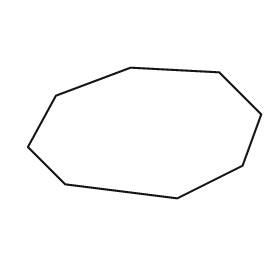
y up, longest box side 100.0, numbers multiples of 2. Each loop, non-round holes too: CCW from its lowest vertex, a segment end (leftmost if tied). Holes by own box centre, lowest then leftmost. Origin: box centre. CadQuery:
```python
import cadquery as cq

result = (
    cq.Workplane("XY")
    .moveTo(14.0, -28.0)
    .lineTo(42.0, -14.0)
    .lineTo(50.0, 8.0)
    .lineTo(32.0, 26.0)
    .lineTo(-6.0, 28.0)
    .lineTo(-38.0, 16.0)
    .lineTo(-50.0, -6.0)
    .lineTo(-34.0, -22.0)
    .close()
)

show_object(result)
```